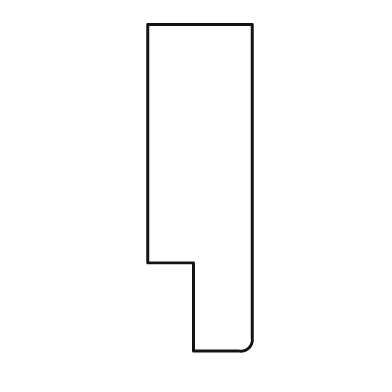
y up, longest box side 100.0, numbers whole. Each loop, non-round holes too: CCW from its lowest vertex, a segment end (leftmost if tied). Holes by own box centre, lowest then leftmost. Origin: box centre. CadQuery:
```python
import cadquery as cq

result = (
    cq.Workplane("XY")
    .moveTo(-2.0, -50.0)
    .lineTo(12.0, -50.0)
    .threePointArc((15.0, -49.0), (16.0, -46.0))
    .lineTo(16.0, 50.0)
    .lineTo(-16.0, 50.0)
    .lineTo(-16.0, -23.0)
    .lineTo(-2.0, -23.0)
    .close()
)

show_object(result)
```